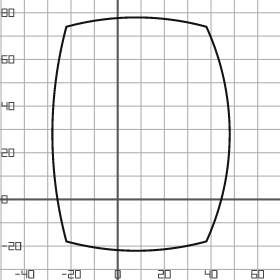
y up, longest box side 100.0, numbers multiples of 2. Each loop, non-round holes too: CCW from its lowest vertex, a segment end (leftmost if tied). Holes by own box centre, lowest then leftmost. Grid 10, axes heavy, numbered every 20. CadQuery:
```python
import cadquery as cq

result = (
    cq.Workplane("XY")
    .moveTo(-22.0, -18.0)
    .threePointArc((8.0, -22.0), (38.0, -18.0))
    .threePointArc((48.0, 28.0), (38.0, 74.0))
    .threePointArc((8.0, 78.0), (-22.0, 74.0))
    .threePointArc((-28.0, 28.0), (-22.0, -18.0))
    .close()
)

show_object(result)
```